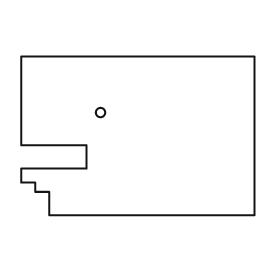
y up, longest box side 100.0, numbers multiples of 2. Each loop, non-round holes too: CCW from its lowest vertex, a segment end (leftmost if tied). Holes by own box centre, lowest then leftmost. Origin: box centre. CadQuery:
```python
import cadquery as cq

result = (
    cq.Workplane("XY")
    .moveTo(-38.0, -34.0)
    .lineTo(50.0, -34.0)
    .lineTo(50.0, 34.0)
    .lineTo(-50.0, 34.0)
    .lineTo(-50.0, -4.0)
    .lineTo(-22.0, -4.0)
    .lineTo(-22.0, -14.0)
    .lineTo(-50.0, -14.0)
    .lineTo(-50.0, -20.0)
    .lineTo(-44.0, -20.0)
    .lineTo(-44.0, -24.0)
    .lineTo(-38.0, -24.0)
    .close()
    .moveTo(-16.0, 10.0)
    .circle(2.0)
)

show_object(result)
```